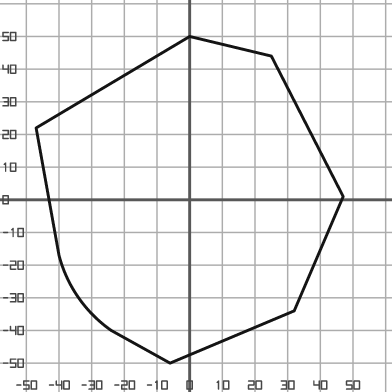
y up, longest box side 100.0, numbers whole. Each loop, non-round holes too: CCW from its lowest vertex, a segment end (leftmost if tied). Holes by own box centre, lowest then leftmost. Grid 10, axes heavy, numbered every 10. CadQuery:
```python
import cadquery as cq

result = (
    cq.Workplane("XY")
    .moveTo(-6.0, -50.0)
    .lineTo(32.0, -34.0)
    .lineTo(47.0, 1.0)
    .lineTo(25.0, 44.0)
    .lineTo(0.0, 50.0)
    .lineTo(-47.0, 22.0)
    .lineTo(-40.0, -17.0)
    .threePointArc((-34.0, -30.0), (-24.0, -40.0))
    .close()
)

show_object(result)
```